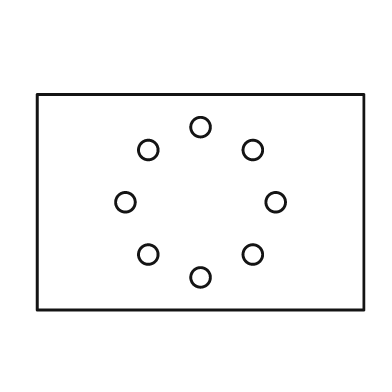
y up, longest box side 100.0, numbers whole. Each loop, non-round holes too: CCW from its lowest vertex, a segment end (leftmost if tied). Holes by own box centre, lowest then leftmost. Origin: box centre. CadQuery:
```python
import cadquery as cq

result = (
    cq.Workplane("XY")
    .moveTo(-50.0, -33.0)
    .lineTo(50.0, -33.0)
    .lineTo(50.0, 33.0)
    .lineTo(-50.0, 33.0)
    .close()
    .moveTo(0.0, -23.0)
    .circle(3.0)
    .moveTo(-16.0, -16.0)
    .circle(3.0)
    .moveTo(16.0, -16.0)
    .circle(3.0)
    .moveTo(-23.0, 0.0)
    .circle(3.0)
    .moveTo(23.0, 0.0)
    .circle(3.0)
    .moveTo(-16.0, 16.0)
    .circle(3.0)
    .moveTo(16.0, 16.0)
    .circle(3.0)
    .moveTo(0.0, 23.0)
    .circle(3.0)
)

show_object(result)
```